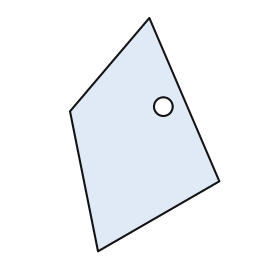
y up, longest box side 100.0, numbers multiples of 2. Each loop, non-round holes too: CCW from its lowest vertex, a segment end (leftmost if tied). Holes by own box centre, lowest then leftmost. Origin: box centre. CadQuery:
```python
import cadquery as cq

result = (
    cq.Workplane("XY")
    .moveTo(-20.0, -50.0)
    .lineTo(32.0, -20.0)
    .lineTo(2.0, 50.0)
    .lineTo(-32.0, 10.0)
    .close()
    .moveTo(8.0, 12.0)
    .circle(4.0)
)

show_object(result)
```